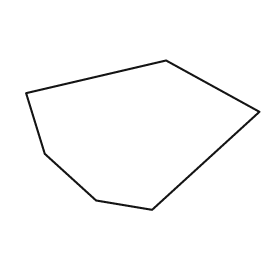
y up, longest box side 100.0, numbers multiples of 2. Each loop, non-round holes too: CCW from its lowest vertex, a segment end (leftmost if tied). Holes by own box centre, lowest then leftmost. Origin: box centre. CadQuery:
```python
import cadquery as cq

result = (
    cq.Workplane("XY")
    .moveTo(4.0, -32.0)
    .lineTo(50.0, 10.0)
    .lineTo(10.0, 32.0)
    .lineTo(-50.0, 18.0)
    .lineTo(-42.0, -8.0)
    .lineTo(-20.0, -28.0)
    .close()
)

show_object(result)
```